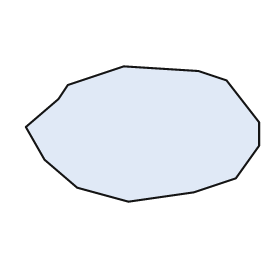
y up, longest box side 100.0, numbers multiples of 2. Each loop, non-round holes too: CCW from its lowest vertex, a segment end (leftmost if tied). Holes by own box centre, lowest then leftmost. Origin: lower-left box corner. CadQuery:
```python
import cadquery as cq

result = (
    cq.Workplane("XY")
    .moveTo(44.0, 0.0)
    .lineTo(72.0, 4.0)
    .lineTo(90.0, 10.0)
    .lineTo(100.0, 24.0)
    .lineTo(100.0, 34.0)
    .lineTo(86.0, 52.0)
    .lineTo(74.0, 56.0)
    .lineTo(42.0, 58.0)
    .lineTo(18.0, 50.0)
    .lineTo(14.0, 44.0)
    .lineTo(0.0, 32.0)
    .lineTo(8.0, 18.0)
    .lineTo(22.0, 6.0)
    .close()
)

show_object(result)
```